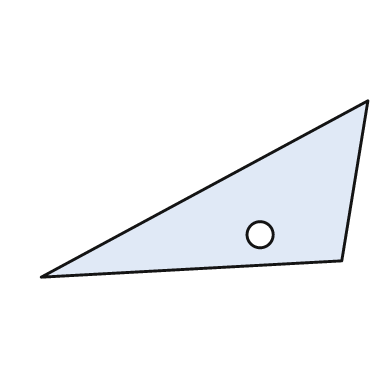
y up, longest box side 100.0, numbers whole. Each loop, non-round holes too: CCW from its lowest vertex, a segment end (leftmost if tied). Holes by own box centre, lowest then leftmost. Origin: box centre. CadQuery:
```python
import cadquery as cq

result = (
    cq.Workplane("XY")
    .moveTo(-50.0, -27.0)
    .lineTo(42.0, -22.0)
    .lineTo(50.0, 27.0)
    .close()
    .moveTo(17.0, -14.0)
    .circle(4.0)
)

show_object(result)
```